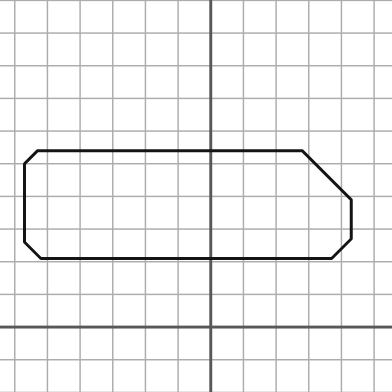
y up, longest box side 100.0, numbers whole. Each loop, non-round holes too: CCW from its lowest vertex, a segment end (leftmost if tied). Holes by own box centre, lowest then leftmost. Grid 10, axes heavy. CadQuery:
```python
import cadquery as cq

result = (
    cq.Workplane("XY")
    .moveTo(-52.0, 21.0)
    .lineTo(37.0, 21.0)
    .lineTo(43.0, 27.0)
    .lineTo(43.0, 39.0)
    .lineTo(28.0, 54.0)
    .lineTo(-53.0, 54.0)
    .lineTo(-57.0, 50.0)
    .lineTo(-57.0, 26.0)
    .close()
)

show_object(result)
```